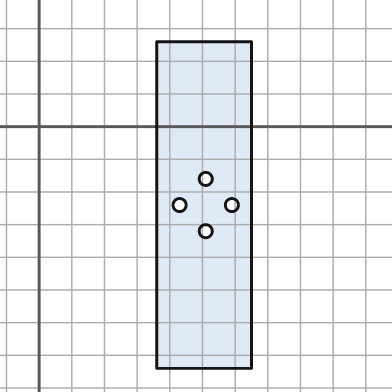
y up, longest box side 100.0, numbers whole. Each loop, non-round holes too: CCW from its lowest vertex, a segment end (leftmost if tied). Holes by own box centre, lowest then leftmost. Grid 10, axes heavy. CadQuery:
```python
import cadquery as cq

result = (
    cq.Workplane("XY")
    .moveTo(36.0, -74.0)
    .lineTo(65.0, -74.0)
    .lineTo(65.0, 26.0)
    .lineTo(36.0, 26.0)
    .close()
    .moveTo(51.0, -32.0)
    .circle(2.0)
    .moveTo(43.0, -24.0)
    .circle(2.0)
    .moveTo(59.0, -24.0)
    .circle(2.0)
    .moveTo(51.0, -16.0)
    .circle(2.0)
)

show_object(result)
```